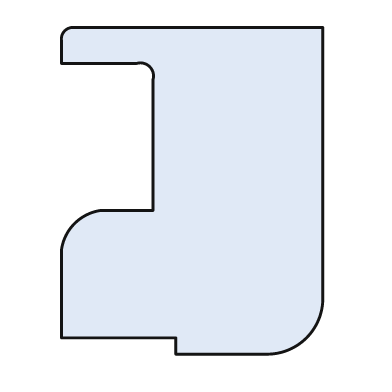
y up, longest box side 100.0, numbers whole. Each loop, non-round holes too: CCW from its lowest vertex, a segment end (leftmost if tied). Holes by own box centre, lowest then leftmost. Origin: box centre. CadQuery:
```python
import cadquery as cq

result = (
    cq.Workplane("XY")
    .moveTo(-5.0, -50.0)
    .lineTo(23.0, -50.0)
    .threePointArc((35.0, -45.0), (40.0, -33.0))
    .lineTo(40.0, 50.0)
    .lineTo(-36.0, 50.0)
    .threePointArc((-39.0, 49.0), (-40.0, 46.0))
    .lineTo(-40.0, 39.0)
    .lineTo(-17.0, 39.0)
    .threePointArc((-13.0, 38.0), (-12.0, 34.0))
    .lineTo(-12.0, -6.0)
    .lineTo(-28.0, -6.0)
    .threePointArc((-36.0, -10.0), (-40.0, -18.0))
    .lineTo(-40.0, -45.0)
    .lineTo(-5.0, -45.0)
    .close()
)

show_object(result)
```